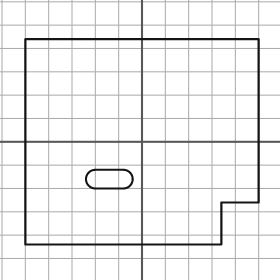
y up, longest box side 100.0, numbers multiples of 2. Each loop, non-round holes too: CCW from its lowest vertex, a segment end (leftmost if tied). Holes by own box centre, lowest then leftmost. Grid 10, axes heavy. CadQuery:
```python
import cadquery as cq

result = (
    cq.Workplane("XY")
    .moveTo(-50.0, -44.0)
    .lineTo(34.0, -44.0)
    .lineTo(34.0, -26.0)
    .lineTo(50.0, -26.0)
    .lineTo(50.0, 44.0)
    .lineTo(-50.0, 44.0)
    .close()
    .moveTo(-20.0, -20.0)
    .lineTo(-8.0, -20.0)
    .threePointArc((-4.0, -16.0), (-8.0, -12.0))
    .lineTo(-20.0, -12.0)
    .threePointArc((-24.0, -16.0), (-20.0, -20.0))
    .close()
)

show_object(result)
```